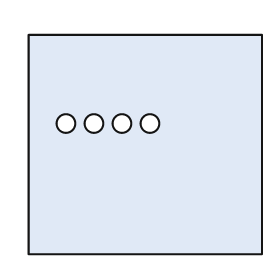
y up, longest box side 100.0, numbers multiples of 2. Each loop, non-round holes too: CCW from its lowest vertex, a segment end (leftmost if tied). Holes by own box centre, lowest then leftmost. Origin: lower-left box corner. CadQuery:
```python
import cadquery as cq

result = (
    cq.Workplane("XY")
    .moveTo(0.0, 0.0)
    .lineTo(100.0, 0.0)
    .lineTo(100.0, 94.0)
    .lineTo(0.0, 94.0)
    .close()
    .moveTo(16.0, 56.0)
    .circle(4.0)
    .moveTo(28.0, 56.0)
    .circle(4.0)
    .moveTo(40.0, 56.0)
    .circle(4.0)
    .moveTo(52.0, 56.0)
    .circle(4.0)
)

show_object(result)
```